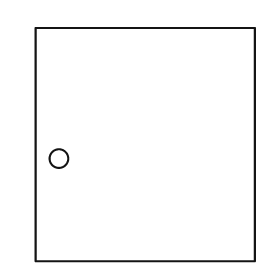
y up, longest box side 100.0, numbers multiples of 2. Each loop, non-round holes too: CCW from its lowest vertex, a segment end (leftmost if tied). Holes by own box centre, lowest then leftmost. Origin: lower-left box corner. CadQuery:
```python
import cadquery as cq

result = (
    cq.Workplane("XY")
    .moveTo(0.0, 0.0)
    .lineTo(94.0, 0.0)
    .lineTo(94.0, 100.0)
    .lineTo(0.0, 100.0)
    .close()
    .moveTo(10.0, 44.0)
    .circle(4.0)
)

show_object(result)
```